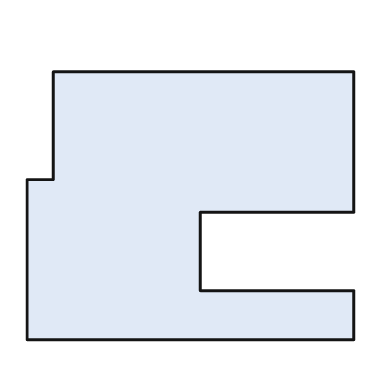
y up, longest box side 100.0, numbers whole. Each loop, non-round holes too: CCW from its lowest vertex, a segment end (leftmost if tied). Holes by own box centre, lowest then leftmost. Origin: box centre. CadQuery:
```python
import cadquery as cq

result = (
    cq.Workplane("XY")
    .moveTo(-50.0, -41.0)
    .lineTo(50.0, -41.0)
    .lineTo(50.0, -26.0)
    .lineTo(3.0, -26.0)
    .lineTo(3.0, -2.0)
    .lineTo(50.0, -2.0)
    .lineTo(50.0, 41.0)
    .lineTo(-42.0, 41.0)
    .lineTo(-42.0, 8.0)
    .lineTo(-50.0, 8.0)
    .close()
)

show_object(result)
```